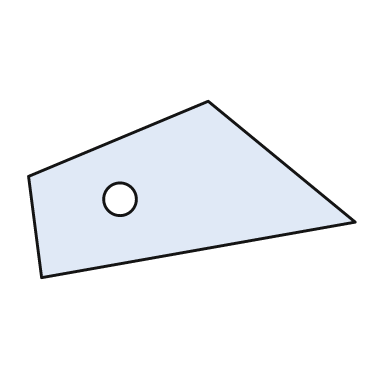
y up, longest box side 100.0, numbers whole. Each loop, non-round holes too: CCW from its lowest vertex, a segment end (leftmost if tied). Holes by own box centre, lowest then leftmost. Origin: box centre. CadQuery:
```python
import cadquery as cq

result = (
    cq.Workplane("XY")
    .moveTo(-46.0, -27.0)
    .lineTo(50.0, -10.0)
    .lineTo(5.0, 27.0)
    .lineTo(-50.0, 4.0)
    .close()
    .moveTo(-22.0, -3.0)
    .circle(5.0)
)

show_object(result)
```